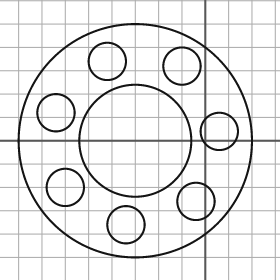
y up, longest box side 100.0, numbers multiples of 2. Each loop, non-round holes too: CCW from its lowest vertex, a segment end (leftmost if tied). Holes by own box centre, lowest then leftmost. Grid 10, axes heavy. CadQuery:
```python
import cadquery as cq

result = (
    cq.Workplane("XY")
    .moveTo(-30.0, 0.0)
    .circle(50.0)
    .moveTo(-34.0, -36.0)
    .circle(8.0)
    .moveTo(-4.0, -26.0)
    .circle(8.0)
    .moveTo(-60.0, -20.0)
    .circle(8.0)
    .moveTo(-30.0, 0.0)
    .circle(24.0)
    .moveTo(6.0, 4.0)
    .circle(8.0)
    .moveTo(-64.0, 12.0)
    .circle(8.0)
    .moveTo(-10.0, 32.0)
    .circle(8.0)
    .moveTo(-42.0, 34.0)
    .circle(8.0)
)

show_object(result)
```